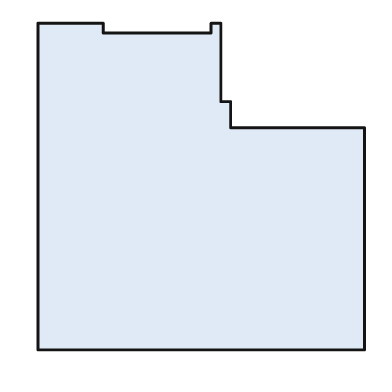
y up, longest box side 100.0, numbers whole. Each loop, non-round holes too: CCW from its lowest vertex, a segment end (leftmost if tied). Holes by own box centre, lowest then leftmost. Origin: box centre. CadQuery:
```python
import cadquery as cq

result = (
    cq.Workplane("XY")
    .moveTo(-50.0, -50.0)
    .lineTo(50.0, -50.0)
    .lineTo(50.0, 18.0)
    .lineTo(9.0, 18.0)
    .lineTo(9.0, 26.0)
    .lineTo(6.0, 26.0)
    .lineTo(6.0, 50.0)
    .lineTo(3.0, 50.0)
    .lineTo(3.0, 47.0)
    .lineTo(-30.0, 47.0)
    .lineTo(-30.0, 50.0)
    .lineTo(-50.0, 50.0)
    .close()
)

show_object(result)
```